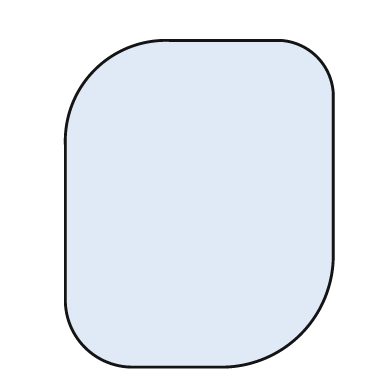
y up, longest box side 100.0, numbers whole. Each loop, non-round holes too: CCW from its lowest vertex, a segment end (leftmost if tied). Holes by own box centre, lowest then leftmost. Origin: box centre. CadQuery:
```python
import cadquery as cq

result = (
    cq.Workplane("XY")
    .moveTo(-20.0, -50.0)
    .lineTo(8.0, -50.0)
    .threePointArc((31.0, -40.0), (41.0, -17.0))
    .lineTo(41.0, 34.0)
    .threePointArc((36.0, 45.0), (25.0, 50.0))
    .lineTo(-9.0, 50.0)
    .threePointArc((-32.0, 41.0), (-41.0, 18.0))
    .lineTo(-41.0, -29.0)
    .threePointArc((-35.0, -44.0), (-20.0, -50.0))
    .close()
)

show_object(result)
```